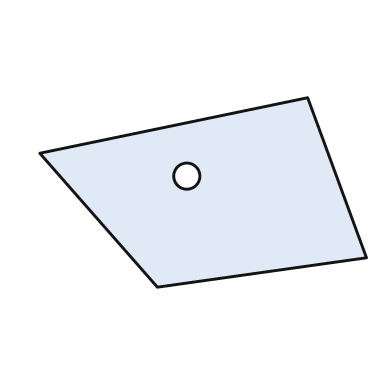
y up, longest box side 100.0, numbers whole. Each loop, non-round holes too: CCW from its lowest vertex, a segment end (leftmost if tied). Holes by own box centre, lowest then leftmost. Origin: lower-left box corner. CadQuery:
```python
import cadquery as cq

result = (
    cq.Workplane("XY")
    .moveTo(36.0, 0.0)
    .lineTo(100.0, 9.0)
    .lineTo(82.0, 58.0)
    .lineTo(0.0, 41.0)
    .close()
    .moveTo(45.0, 34.0)
    .circle(4.0)
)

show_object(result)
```